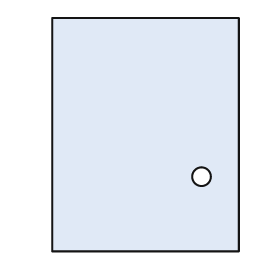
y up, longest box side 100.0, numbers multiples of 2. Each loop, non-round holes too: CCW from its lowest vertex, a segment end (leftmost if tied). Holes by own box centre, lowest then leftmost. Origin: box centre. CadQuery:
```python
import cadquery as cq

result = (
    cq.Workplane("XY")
    .moveTo(-40.0, -50.0)
    .lineTo(40.0, -50.0)
    .lineTo(40.0, 50.0)
    .lineTo(-40.0, 50.0)
    .close()
    .moveTo(24.0, -18.0)
    .circle(4.0)
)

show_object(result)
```